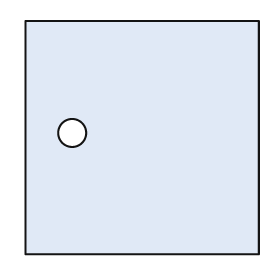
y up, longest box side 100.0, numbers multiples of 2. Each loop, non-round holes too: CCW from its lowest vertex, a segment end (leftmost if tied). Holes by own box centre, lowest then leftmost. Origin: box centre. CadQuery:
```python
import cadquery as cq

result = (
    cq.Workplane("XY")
    .moveTo(-50.0, -50.0)
    .lineTo(50.0, -50.0)
    .lineTo(50.0, 50.0)
    .lineTo(-50.0, 50.0)
    .close()
    .moveTo(-30.0, 2.0)
    .circle(6.0)
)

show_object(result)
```